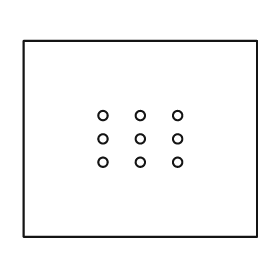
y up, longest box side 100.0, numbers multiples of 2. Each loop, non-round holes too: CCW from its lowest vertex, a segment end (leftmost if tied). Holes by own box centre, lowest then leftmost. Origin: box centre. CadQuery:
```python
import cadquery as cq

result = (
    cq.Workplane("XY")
    .moveTo(-50.0, -42.0)
    .lineTo(50.0, -42.0)
    .lineTo(50.0, 42.0)
    .lineTo(-50.0, 42.0)
    .close()
    .moveTo(-16.0, -10.0)
    .circle(2.0)
    .moveTo(0.0, -10.0)
    .circle(2.0)
    .moveTo(16.0, -10.0)
    .circle(2.0)
    .moveTo(-16.0, 0.0)
    .circle(2.0)
    .moveTo(0.0, 0.0)
    .circle(2.0)
    .moveTo(16.0, 0.0)
    .circle(2.0)
    .moveTo(-16.0, 10.0)
    .circle(2.0)
    .moveTo(0.0, 10.0)
    .circle(2.0)
    .moveTo(16.0, 10.0)
    .circle(2.0)
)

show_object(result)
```